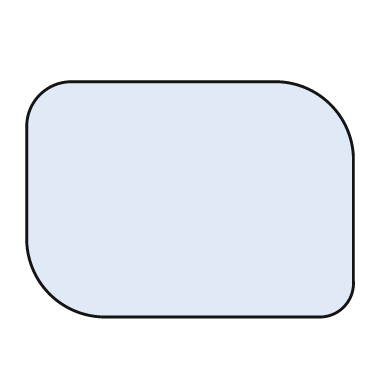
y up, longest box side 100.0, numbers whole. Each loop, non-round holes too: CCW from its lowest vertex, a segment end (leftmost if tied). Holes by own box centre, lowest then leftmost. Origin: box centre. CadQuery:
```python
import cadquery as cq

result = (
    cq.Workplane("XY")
    .moveTo(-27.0, -36.0)
    .lineTo(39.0, -36.0)
    .threePointArc((47.0, -33.0), (50.0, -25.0))
    .lineTo(50.0, 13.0)
    .threePointArc((43.0, 29.0), (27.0, 36.0))
    .lineTo(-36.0, 36.0)
    .threePointArc((-46.0, 32.0), (-50.0, 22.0))
    .lineTo(-50.0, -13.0)
    .threePointArc((-43.0, -29.0), (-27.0, -36.0))
    .close()
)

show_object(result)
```